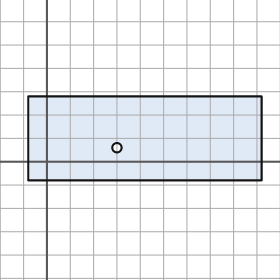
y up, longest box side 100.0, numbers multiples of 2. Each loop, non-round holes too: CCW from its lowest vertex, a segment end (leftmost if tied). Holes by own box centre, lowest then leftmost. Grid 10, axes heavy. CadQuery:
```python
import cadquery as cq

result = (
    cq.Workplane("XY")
    .moveTo(-8.0, -8.0)
    .lineTo(92.0, -8.0)
    .lineTo(92.0, 28.0)
    .lineTo(-8.0, 28.0)
    .close()
    .moveTo(30.0, 6.0)
    .circle(2.0)
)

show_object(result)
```